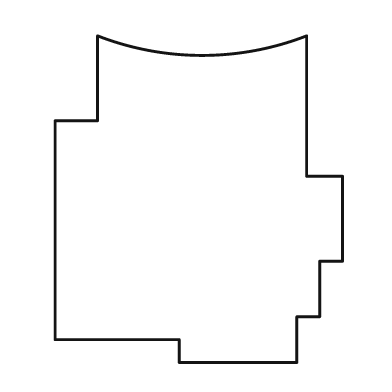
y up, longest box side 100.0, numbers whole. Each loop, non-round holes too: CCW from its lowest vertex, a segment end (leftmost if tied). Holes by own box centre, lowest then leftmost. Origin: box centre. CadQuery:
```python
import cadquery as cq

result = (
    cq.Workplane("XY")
    .moveTo(-6.0, -50.0)
    .lineTo(30.0, -50.0)
    .lineTo(30.0, -36.0)
    .lineTo(37.0, -36.0)
    .lineTo(37.0, -19.0)
    .lineTo(44.0, -19.0)
    .lineTo(44.0, 7.0)
    .lineTo(33.0, 7.0)
    .lineTo(33.0, 50.0)
    .threePointArc((1.0, 44.0), (-31.0, 50.0))
    .lineTo(-31.0, 24.0)
    .lineTo(-44.0, 24.0)
    .lineTo(-44.0, -43.0)
    .lineTo(-6.0, -43.0)
    .close()
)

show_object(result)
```